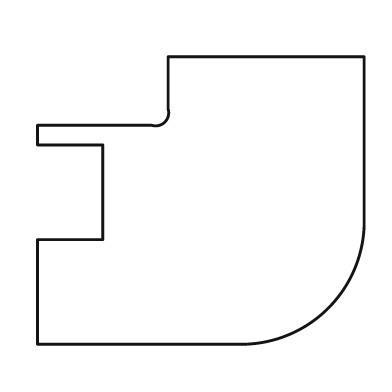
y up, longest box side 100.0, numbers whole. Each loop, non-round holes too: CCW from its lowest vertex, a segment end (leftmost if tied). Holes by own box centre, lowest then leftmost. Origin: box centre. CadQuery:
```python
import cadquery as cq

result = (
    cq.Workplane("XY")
    .moveTo(-50.0, -44.0)
    .lineTo(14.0, -44.0)
    .threePointArc((39.0, -33.0), (50.0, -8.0))
    .lineTo(50.0, 44.0)
    .lineTo(-10.0, 44.0)
    .lineTo(-10.0, 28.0)
    .threePointArc((-11.0, 24.0), (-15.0, 23.0))
    .lineTo(-50.0, 23.0)
    .lineTo(-50.0, 17.0)
    .lineTo(-30.0, 17.0)
    .lineTo(-30.0, -12.0)
    .lineTo(-50.0, -12.0)
    .close()
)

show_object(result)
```